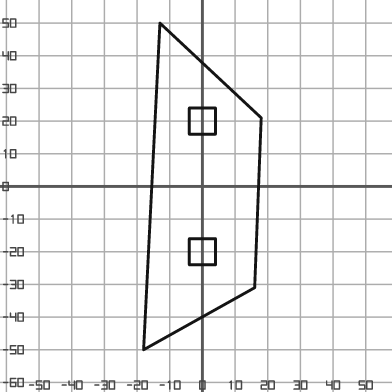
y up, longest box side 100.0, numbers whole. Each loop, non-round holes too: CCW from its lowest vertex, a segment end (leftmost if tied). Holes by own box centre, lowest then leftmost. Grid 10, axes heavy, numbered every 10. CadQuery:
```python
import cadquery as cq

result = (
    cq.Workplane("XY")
    .moveTo(-18.0, -50.0)
    .lineTo(16.0, -31.0)
    .lineTo(18.0, 21.0)
    .lineTo(-13.0, 50.0)
    .close()
    .moveTo(-4.0, -24.0)
    .lineTo(4.0, -24.0)
    .lineTo(4.0, -16.0)
    .lineTo(-4.0, -16.0)
    .close()
    .moveTo(-4.0, 16.0)
    .lineTo(4.0, 16.0)
    .lineTo(4.0, 24.0)
    .lineTo(-4.0, 24.0)
    .close()
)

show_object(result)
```